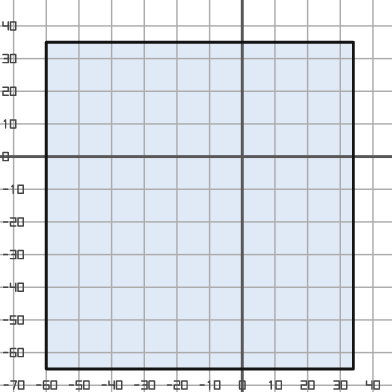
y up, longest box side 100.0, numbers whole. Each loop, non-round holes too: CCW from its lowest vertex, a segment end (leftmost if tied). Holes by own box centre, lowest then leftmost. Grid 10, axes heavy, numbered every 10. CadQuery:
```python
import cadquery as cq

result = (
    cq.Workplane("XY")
    .moveTo(-60.0, -65.0)
    .lineTo(34.0, -65.0)
    .lineTo(34.0, 35.0)
    .lineTo(-60.0, 35.0)
    .close()
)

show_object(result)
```